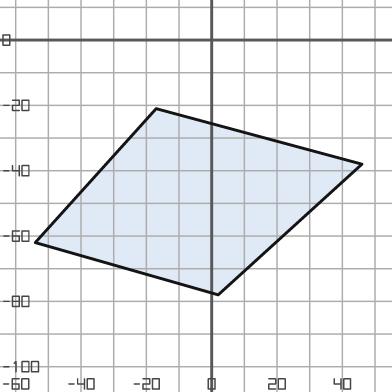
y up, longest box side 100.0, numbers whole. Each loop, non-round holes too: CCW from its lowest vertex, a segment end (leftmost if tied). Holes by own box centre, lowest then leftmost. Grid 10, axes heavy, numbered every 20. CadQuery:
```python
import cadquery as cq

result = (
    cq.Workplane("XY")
    .moveTo(2.0, -78.0)
    .lineTo(46.0, -38.0)
    .lineTo(-17.0, -21.0)
    .lineTo(-54.0, -62.0)
    .close()
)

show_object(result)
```